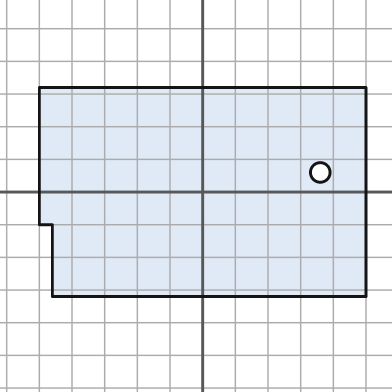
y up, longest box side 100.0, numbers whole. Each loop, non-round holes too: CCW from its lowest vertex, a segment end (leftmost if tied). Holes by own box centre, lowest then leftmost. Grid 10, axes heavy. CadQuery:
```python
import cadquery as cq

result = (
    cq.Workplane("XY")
    .moveTo(-46.0, -32.0)
    .lineTo(50.0, -32.0)
    .lineTo(50.0, 32.0)
    .lineTo(-50.0, 32.0)
    .lineTo(-50.0, -10.0)
    .lineTo(-46.0, -10.0)
    .close()
    .moveTo(36.0, 6.0)
    .circle(3.0)
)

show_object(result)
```